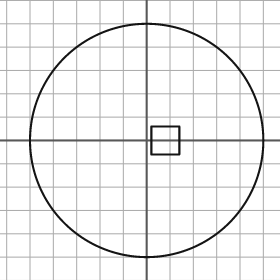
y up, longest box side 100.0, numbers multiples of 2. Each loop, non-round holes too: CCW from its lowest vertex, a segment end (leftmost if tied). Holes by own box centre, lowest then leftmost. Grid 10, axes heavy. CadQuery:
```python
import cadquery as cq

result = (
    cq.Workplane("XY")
    .moveTo(0.0, 0.0)
    .circle(50.0)
    .moveTo(2.0, -6.0)
    .lineTo(14.0, -6.0)
    .lineTo(14.0, 6.0)
    .lineTo(2.0, 6.0)
    .close()
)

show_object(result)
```